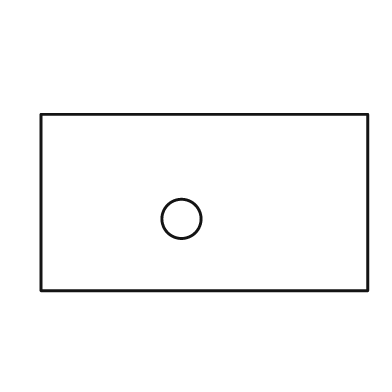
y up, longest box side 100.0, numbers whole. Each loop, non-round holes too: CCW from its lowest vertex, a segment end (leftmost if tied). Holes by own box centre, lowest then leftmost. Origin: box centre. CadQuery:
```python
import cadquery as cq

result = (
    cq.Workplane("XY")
    .moveTo(-50.0, -27.0)
    .lineTo(50.0, -27.0)
    .lineTo(50.0, 27.0)
    .lineTo(-50.0, 27.0)
    .close()
    .moveTo(-7.0, -5.0)
    .circle(6.0)
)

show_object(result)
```